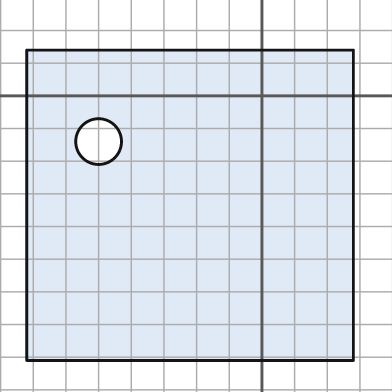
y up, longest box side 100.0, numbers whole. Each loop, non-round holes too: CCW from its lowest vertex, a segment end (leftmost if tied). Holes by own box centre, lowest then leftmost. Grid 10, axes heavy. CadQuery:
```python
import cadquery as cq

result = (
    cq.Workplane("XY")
    .moveTo(-72.0, -81.0)
    .lineTo(28.0, -81.0)
    .lineTo(28.0, 14.0)
    .lineTo(-72.0, 14.0)
    .close()
    .moveTo(-50.0, -14.0)
    .circle(7.0)
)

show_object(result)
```